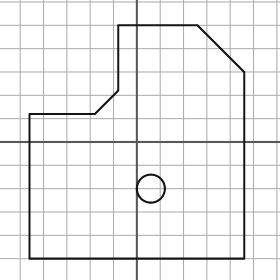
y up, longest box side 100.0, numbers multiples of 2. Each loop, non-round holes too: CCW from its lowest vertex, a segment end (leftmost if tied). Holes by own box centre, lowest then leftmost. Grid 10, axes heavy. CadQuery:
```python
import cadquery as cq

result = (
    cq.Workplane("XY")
    .moveTo(-46.0, -50.0)
    .lineTo(46.0, -50.0)
    .lineTo(46.0, 30.0)
    .lineTo(26.0, 50.0)
    .lineTo(-8.0, 50.0)
    .lineTo(-8.0, 22.0)
    .lineTo(-18.0, 12.0)
    .lineTo(-46.0, 12.0)
    .close()
    .moveTo(6.0, -20.0)
    .circle(6.0)
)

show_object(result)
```